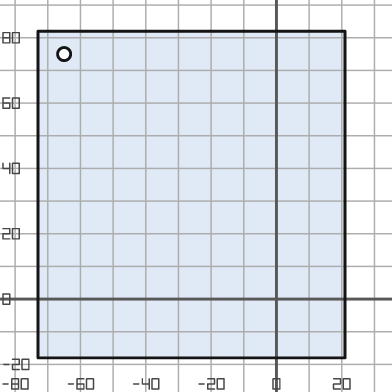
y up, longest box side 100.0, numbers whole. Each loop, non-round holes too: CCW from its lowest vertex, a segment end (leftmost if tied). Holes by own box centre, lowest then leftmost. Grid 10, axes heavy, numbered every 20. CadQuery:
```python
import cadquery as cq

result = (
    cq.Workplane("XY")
    .moveTo(-73.0, -18.0)
    .lineTo(21.0, -18.0)
    .lineTo(21.0, 82.0)
    .lineTo(-73.0, 82.0)
    .close()
    .moveTo(-65.0, 75.0)
    .circle(2.0)
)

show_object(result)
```